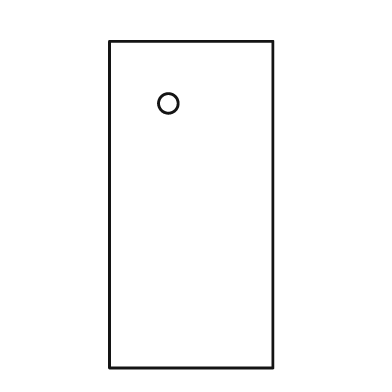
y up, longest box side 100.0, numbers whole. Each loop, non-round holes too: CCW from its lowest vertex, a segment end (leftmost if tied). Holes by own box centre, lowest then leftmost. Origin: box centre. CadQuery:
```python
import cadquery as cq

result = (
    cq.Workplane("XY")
    .moveTo(-25.0, -50.0)
    .lineTo(25.0, -50.0)
    .lineTo(25.0, 50.0)
    .lineTo(-25.0, 50.0)
    .close()
    .moveTo(-7.0, 31.0)
    .circle(3.0)
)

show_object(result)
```